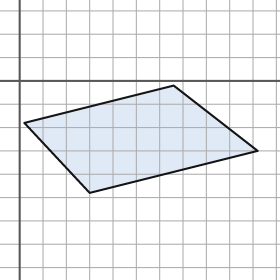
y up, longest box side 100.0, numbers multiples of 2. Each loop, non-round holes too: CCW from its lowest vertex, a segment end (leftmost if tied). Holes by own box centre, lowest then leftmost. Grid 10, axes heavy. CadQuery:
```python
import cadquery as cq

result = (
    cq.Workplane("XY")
    .moveTo(30.0, -48.0)
    .lineTo(102.0, -30.0)
    .lineTo(66.0, -2.0)
    .lineTo(2.0, -18.0)
    .close()
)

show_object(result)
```